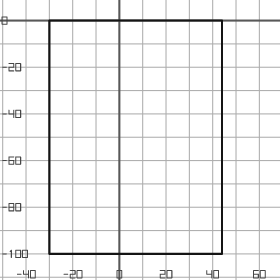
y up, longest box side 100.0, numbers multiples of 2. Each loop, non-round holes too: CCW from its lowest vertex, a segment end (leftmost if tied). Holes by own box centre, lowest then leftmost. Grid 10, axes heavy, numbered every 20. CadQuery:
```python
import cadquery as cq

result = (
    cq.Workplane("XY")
    .moveTo(-30.0, -100.0)
    .lineTo(44.0, -100.0)
    .lineTo(44.0, 0.0)
    .lineTo(-30.0, 0.0)
    .close()
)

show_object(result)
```